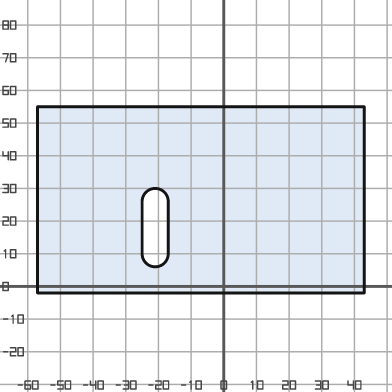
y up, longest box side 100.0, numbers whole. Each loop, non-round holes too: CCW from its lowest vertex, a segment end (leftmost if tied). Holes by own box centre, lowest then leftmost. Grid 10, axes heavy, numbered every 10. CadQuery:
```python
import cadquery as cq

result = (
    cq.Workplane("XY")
    .moveTo(-57.0, -2.0)
    .lineTo(43.0, -2.0)
    .lineTo(43.0, 55.0)
    .lineTo(-57.0, 55.0)
    .close()
    .moveTo(-25.0, 10.0)
    .threePointArc((-21.0, 6.0), (-17.0, 10.0))
    .lineTo(-17.0, 26.0)
    .threePointArc((-21.0, 30.0), (-25.0, 26.0))
    .close()
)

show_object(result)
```